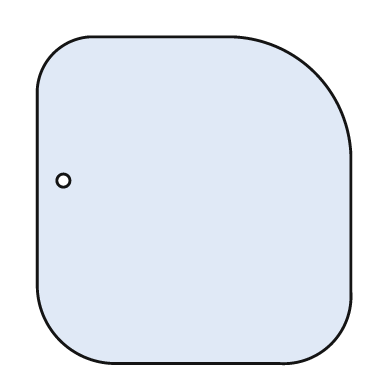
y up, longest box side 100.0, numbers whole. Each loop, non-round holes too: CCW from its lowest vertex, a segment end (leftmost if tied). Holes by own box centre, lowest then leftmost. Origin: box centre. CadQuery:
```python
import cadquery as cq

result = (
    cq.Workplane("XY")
    .moveTo(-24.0, -50.0)
    .lineTo(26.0, -50.0)
    .threePointArc((42.0, -44.0), (48.0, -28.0))
    .lineTo(48.0, 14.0)
    .threePointArc((37.0, 39.0), (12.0, 50.0))
    .lineTo(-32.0, 50.0)
    .threePointArc((-43.0, 45.0), (-48.0, 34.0))
    .lineTo(-48.0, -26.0)
    .threePointArc((-41.0, -43.0), (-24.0, -50.0))
    .close()
    .moveTo(-40.0, 6.0)
    .circle(2.0)
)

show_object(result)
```